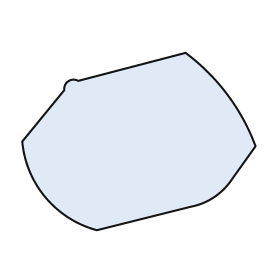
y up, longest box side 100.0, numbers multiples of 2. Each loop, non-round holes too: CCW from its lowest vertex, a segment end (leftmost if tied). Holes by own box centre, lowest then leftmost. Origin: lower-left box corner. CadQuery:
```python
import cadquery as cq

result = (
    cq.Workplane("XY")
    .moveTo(32.0, 0.0)
    .lineTo(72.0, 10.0)
    .threePointArc((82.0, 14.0), (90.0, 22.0))
    .lineTo(100.0, 36.0)
    .threePointArc((88.0, 58.0), (70.0, 76.0))
    .lineTo(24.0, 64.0)
    .threePointArc((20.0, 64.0), (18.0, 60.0))
    .lineTo(0.0, 38.0)
    .threePointArc((10.0, 14.0), (32.0, 0.0))
    .close()
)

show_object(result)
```